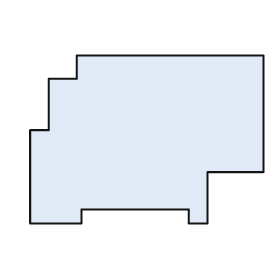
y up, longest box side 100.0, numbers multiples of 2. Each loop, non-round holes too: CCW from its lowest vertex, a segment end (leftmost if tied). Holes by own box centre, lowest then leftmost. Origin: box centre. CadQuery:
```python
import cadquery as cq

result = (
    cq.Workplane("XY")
    .moveTo(-50.0, -36.0)
    .lineTo(-28.0, -36.0)
    .lineTo(-28.0, -30.0)
    .lineTo(18.0, -30.0)
    .lineTo(18.0, -36.0)
    .lineTo(26.0, -36.0)
    .lineTo(26.0, -14.0)
    .lineTo(50.0, -14.0)
    .lineTo(50.0, 36.0)
    .lineTo(-30.0, 36.0)
    .lineTo(-30.0, 26.0)
    .lineTo(-42.0, 26.0)
    .lineTo(-42.0, 4.0)
    .lineTo(-50.0, 4.0)
    .close()
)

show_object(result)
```